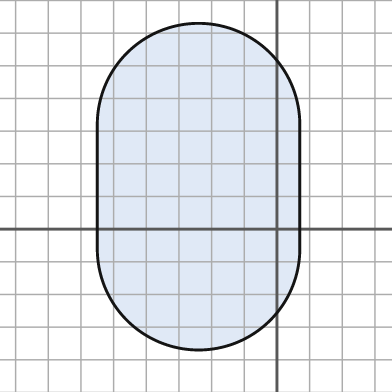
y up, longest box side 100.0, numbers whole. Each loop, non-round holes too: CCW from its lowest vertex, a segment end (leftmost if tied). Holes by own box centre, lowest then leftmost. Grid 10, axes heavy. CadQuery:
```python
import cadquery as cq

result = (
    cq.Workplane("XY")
    .moveTo(-55.0, -6.0)
    .threePointArc((-24.0, -37.0), (7.0, -6.0))
    .lineTo(7.0, 32.0)
    .threePointArc((-24.0, 63.0), (-55.0, 32.0))
    .close()
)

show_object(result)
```